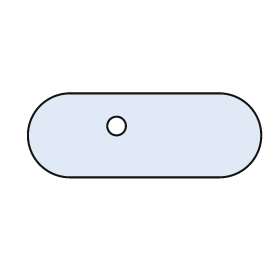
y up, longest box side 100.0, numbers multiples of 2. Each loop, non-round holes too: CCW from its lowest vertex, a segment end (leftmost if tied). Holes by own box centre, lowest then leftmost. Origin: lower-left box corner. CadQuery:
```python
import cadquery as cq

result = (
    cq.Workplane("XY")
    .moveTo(18.0, 0.0)
    .lineTo(82.0, 0.0)
    .threePointArc((100.0, 18.0), (82.0, 36.0))
    .lineTo(18.0, 36.0)
    .threePointArc((0.0, 18.0), (18.0, 0.0))
    .close()
    .moveTo(38.0, 22.0)
    .circle(4.0)
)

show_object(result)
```